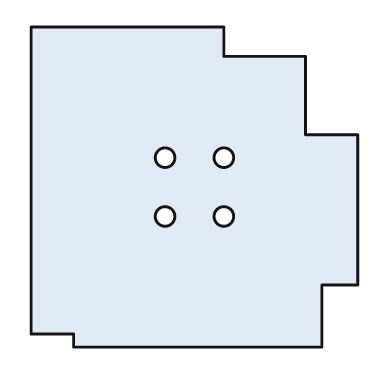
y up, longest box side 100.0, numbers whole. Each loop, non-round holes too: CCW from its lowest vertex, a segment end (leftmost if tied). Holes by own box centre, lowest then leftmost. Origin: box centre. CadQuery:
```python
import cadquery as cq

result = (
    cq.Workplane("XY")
    .moveTo(-37.0, -49.0)
    .lineTo(39.0, -49.0)
    .lineTo(39.0, -30.0)
    .lineTo(50.0, -30.0)
    .lineTo(50.0, 16.0)
    .lineTo(34.0, 16.0)
    .lineTo(34.0, 40.0)
    .lineTo(9.0, 40.0)
    .lineTo(9.0, 49.0)
    .lineTo(-50.0, 49.0)
    .lineTo(-50.0, -45.0)
    .lineTo(-37.0, -45.0)
    .close()
    .moveTo(-9.0, -9.0)
    .circle(3.0)
    .moveTo(9.0, -9.0)
    .circle(3.0)
    .moveTo(-9.0, 9.0)
    .circle(3.0)
    .moveTo(9.0, 9.0)
    .circle(3.0)
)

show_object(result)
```